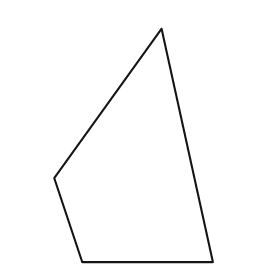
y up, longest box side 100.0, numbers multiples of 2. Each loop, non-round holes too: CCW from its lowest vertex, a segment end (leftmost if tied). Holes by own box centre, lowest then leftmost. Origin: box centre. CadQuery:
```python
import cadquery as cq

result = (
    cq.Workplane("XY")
    .moveTo(-22.0, -50.0)
    .lineTo(34.0, -50.0)
    .lineTo(12.0, 50.0)
    .lineTo(-34.0, -14.0)
    .close()
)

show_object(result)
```